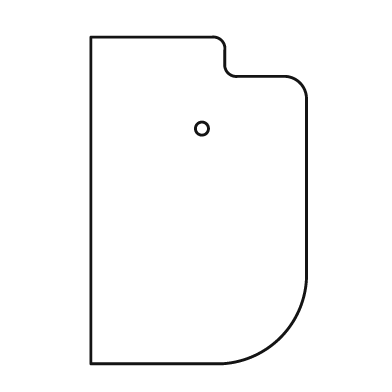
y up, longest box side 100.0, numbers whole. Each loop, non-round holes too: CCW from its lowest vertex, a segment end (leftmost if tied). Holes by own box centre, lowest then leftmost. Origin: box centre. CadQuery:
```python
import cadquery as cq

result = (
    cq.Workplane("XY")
    .moveTo(-33.0, -50.0)
    .lineTo(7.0, -50.0)
    .threePointArc((25.0, -42.0), (33.0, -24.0))
    .lineTo(33.0, 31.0)
    .threePointArc((31.0, 36.0), (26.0, 38.0))
    .lineTo(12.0, 38.0)
    .threePointArc((9.0, 39.0), (8.0, 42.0))
    .lineTo(8.0, 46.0)
    .threePointArc((7.0, 49.0), (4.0, 50.0))
    .lineTo(-33.0, 50.0)
    .close()
    .moveTo(1.0, 22.0)
    .circle(2.0)
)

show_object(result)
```